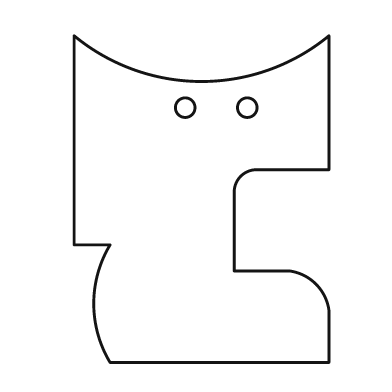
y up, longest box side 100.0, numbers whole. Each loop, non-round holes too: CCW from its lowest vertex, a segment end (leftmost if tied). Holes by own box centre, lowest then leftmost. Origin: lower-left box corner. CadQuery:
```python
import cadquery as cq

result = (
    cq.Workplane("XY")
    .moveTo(11.0, 0.0)
    .lineTo(78.0, 0.0)
    .lineTo(78.0, 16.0)
    .threePointArc((74.0, 24.0), (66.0, 28.0))
    .lineTo(49.0, 28.0)
    .lineTo(49.0, 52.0)
    .threePointArc((51.0, 57.0), (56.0, 59.0))
    .lineTo(78.0, 59.0)
    .lineTo(78.0, 100.0)
    .threePointArc((39.0, 86.0), (0.0, 100.0))
    .lineTo(0.0, 36.0)
    .lineTo(11.0, 36.0)
    .threePointArc((6.0, 18.0), (11.0, 0.0))
    .close()
    .moveTo(34.0, 78.0)
    .circle(3.0)
    .moveTo(53.0, 78.0)
    .circle(3.0)
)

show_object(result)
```